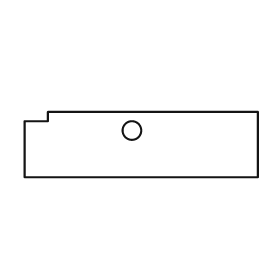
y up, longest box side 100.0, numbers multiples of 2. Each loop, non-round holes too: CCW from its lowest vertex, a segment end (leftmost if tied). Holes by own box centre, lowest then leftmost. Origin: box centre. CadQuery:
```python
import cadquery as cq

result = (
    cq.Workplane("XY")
    .moveTo(-50.0, -14.0)
    .lineTo(50.0, -14.0)
    .lineTo(50.0, 14.0)
    .lineTo(-40.0, 14.0)
    .lineTo(-40.0, 10.0)
    .lineTo(-50.0, 10.0)
    .close()
    .moveTo(-4.0, 6.0)
    .circle(4.0)
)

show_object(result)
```